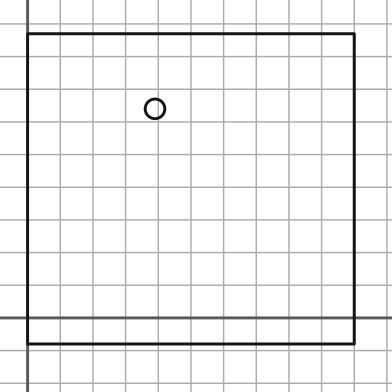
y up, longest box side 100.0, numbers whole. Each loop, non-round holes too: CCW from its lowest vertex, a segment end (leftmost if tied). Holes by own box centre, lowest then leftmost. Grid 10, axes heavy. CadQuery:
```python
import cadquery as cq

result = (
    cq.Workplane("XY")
    .moveTo(0.0, -8.0)
    .lineTo(100.0, -8.0)
    .lineTo(100.0, 87.0)
    .lineTo(0.0, 87.0)
    .close()
    .moveTo(39.0, 64.0)
    .circle(3.0)
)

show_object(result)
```